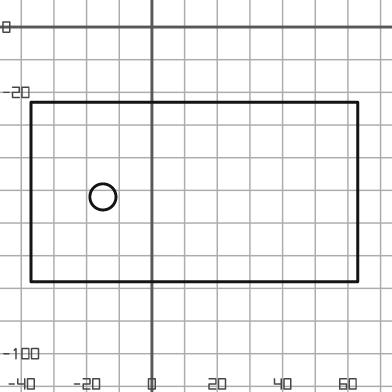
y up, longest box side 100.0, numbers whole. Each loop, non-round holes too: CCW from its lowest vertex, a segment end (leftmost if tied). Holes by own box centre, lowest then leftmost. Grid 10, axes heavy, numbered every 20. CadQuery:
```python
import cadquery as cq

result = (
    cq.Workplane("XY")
    .moveTo(-37.0, -78.0)
    .lineTo(63.0, -78.0)
    .lineTo(63.0, -23.0)
    .lineTo(-37.0, -23.0)
    .close()
    .moveTo(-15.0, -52.0)
    .circle(4.0)
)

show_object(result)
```